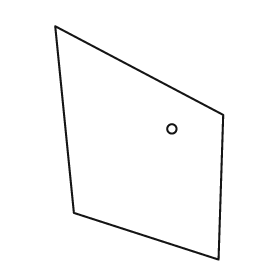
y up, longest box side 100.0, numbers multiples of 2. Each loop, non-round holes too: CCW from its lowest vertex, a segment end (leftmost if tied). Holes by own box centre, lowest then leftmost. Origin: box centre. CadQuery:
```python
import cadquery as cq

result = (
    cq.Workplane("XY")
    .moveTo(34.0, -50.0)
    .lineTo(36.0, 12.0)
    .lineTo(-36.0, 50.0)
    .lineTo(-28.0, -30.0)
    .close()
    .moveTo(14.0, 6.0)
    .circle(2.0)
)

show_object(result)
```